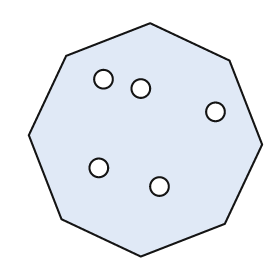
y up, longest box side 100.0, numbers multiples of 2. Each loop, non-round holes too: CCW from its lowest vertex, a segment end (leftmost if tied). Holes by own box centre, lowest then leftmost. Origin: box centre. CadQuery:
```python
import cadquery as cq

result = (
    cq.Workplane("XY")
    .moveTo(-2.0, -50.0)
    .lineTo(34.0, -36.0)
    .lineTo(50.0, -2.0)
    .lineTo(36.0, 34.0)
    .lineTo(2.0, 50.0)
    .lineTo(-34.0, 36.0)
    .lineTo(-50.0, 2.0)
    .lineTo(-36.0, -34.0)
    .close()
    .moveTo(6.0, -20.0)
    .circle(4.0)
    .moveTo(-20.0, -12.0)
    .circle(4.0)
    .moveTo(30.0, 12.0)
    .circle(4.0)
    .moveTo(-2.0, 22.0)
    .circle(4.0)
    .moveTo(-18.0, 26.0)
    .circle(4.0)
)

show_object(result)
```